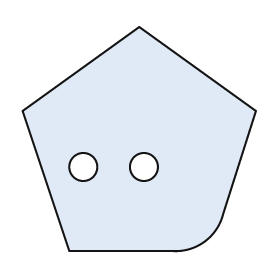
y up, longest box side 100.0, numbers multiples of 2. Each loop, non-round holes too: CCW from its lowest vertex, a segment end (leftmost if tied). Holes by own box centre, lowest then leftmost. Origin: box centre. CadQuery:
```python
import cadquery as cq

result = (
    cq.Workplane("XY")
    .moveTo(-30.0, -48.0)
    .lineTo(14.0, -48.0)
    .threePointArc((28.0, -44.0), (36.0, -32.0))
    .lineTo(50.0, 12.0)
    .lineTo(0.0, 48.0)
    .lineTo(-50.0, 12.0)
    .close()
    .moveTo(-24.0, -12.0)
    .circle(6.0)
    .moveTo(2.0, -12.0)
    .circle(6.0)
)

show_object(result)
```